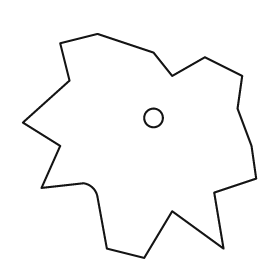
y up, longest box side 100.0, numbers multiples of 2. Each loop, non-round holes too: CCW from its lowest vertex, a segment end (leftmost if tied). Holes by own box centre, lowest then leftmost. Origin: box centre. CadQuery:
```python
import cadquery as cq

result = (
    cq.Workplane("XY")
    .moveTo(2.0, -48.0)
    .lineTo(14.0, -28.0)
    .lineTo(36.0, -44.0)
    .lineTo(32.0, -20.0)
    .lineTo(50.0, -14.0)
    .lineTo(48.0, 0.0)
    .lineTo(42.0, 16.0)
    .lineTo(44.0, 30.0)
    .lineTo(28.0, 38.0)
    .lineTo(14.0, 30.0)
    .lineTo(6.0, 40.0)
    .lineTo(-18.0, 48.0)
    .lineTo(-34.0, 44.0)
    .lineTo(-30.0, 28.0)
    .lineTo(-50.0, 10.0)
    .lineTo(-34.0, 0.0)
    .lineTo(-42.0, -18.0)
    .lineTo(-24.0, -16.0)
    .threePointArc((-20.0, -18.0), (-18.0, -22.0))
    .lineTo(-14.0, -44.0)
    .close()
    .moveTo(6.0, 12.0)
    .circle(4.0)
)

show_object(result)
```